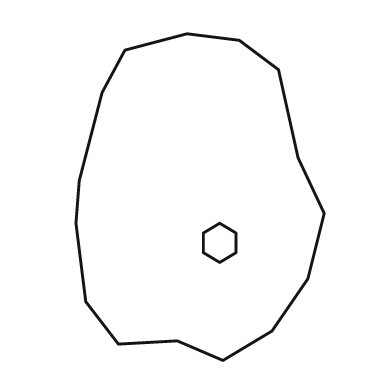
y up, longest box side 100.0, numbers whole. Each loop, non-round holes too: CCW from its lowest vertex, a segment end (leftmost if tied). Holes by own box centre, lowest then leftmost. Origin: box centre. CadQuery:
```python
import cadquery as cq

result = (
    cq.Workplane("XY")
    .moveTo(7.0, -50.0)
    .lineTo(22.0, -41.0)
    .lineTo(33.0, -25.0)
    .lineTo(38.0, -5.0)
    .lineTo(30.0, 12.0)
    .lineTo(24.0, 39.0)
    .lineTo(12.0, 48.0)
    .lineTo(-4.0, 50.0)
    .lineTo(-23.0, 45.0)
    .lineTo(-30.0, 32.0)
    .lineTo(-37.0, 5.0)
    .lineTo(-38.0, -8.0)
    .lineTo(-35.0, -32.0)
    .lineTo(-25.0, -45.0)
    .lineTo(-7.0, -44.0)
    .close()
    .moveTo(6.0, -20.0)
    .lineTo(11.0, -17.0)
    .lineTo(11.0, -11.0)
    .lineTo(6.0, -8.0)
    .lineTo(1.0, -11.0)
    .lineTo(1.0, -17.0)
    .close()
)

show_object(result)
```